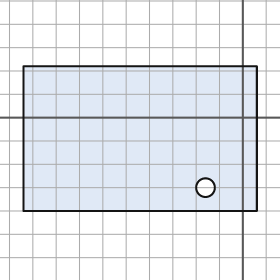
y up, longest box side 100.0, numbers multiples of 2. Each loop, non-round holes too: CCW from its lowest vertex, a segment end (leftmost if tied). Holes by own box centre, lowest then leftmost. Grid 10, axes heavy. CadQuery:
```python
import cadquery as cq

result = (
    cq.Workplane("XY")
    .moveTo(-94.0, -40.0)
    .lineTo(6.0, -40.0)
    .lineTo(6.0, 22.0)
    .lineTo(-94.0, 22.0)
    .close()
    .moveTo(-16.0, -30.0)
    .circle(4.0)
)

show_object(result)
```